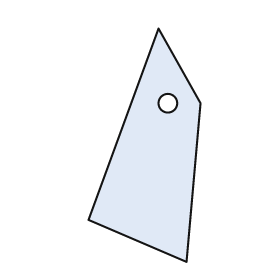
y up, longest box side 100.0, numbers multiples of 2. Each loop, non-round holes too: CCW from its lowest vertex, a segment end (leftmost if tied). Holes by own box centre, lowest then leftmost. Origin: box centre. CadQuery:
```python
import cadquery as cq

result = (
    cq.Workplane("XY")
    .moveTo(18.0, -50.0)
    .lineTo(24.0, 18.0)
    .lineTo(6.0, 50.0)
    .lineTo(-24.0, -32.0)
    .close()
    .moveTo(10.0, 18.0)
    .circle(4.0)
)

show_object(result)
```